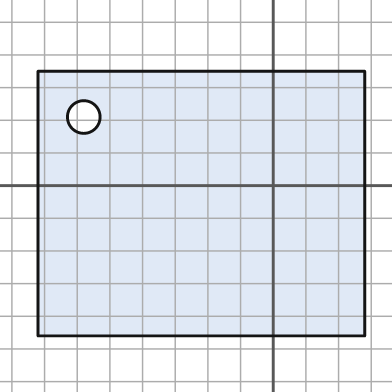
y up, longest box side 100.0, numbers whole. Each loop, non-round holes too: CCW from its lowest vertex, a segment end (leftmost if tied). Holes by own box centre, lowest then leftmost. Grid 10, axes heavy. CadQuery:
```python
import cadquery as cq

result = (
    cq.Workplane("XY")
    .moveTo(-72.0, -46.0)
    .lineTo(28.0, -46.0)
    .lineTo(28.0, 35.0)
    .lineTo(-72.0, 35.0)
    .close()
    .moveTo(-58.0, 21.0)
    .circle(5.0)
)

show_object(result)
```